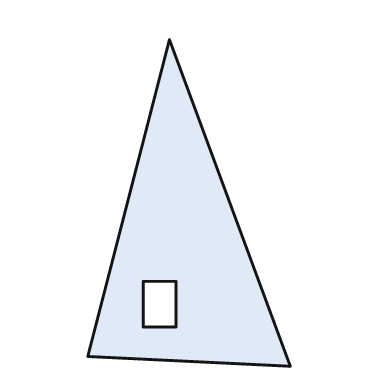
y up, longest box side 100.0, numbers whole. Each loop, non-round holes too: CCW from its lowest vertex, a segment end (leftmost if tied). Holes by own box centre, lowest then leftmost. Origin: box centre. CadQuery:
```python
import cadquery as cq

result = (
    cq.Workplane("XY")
    .moveTo(31.0, -50.0)
    .lineTo(-6.0, 50.0)
    .lineTo(-31.0, -47.0)
    .close()
    .moveTo(-14.0, -38.0)
    .lineTo(-4.0, -38.0)
    .lineTo(-4.0, -24.0)
    .lineTo(-14.0, -24.0)
    .close()
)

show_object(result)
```